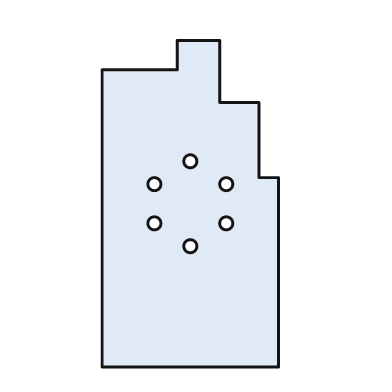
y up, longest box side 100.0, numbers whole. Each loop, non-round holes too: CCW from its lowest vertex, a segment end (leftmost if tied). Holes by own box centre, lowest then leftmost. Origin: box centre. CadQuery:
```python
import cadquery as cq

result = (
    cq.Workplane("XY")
    .moveTo(-27.0, -50.0)
    .lineTo(27.0, -50.0)
    .lineTo(27.0, 8.0)
    .lineTo(21.0, 8.0)
    .lineTo(21.0, 31.0)
    .lineTo(9.0, 31.0)
    .lineTo(9.0, 50.0)
    .lineTo(-4.0, 50.0)
    .lineTo(-4.0, 41.0)
    .lineTo(-27.0, 41.0)
    .close()
    .moveTo(0.0, -13.0)
    .circle(2.0)
    .moveTo(-11.0, -6.0)
    .circle(2.0)
    .moveTo(11.0, -6.0)
    .circle(2.0)
    .moveTo(-11.0, 6.0)
    .circle(2.0)
    .moveTo(11.0, 6.0)
    .circle(2.0)
    .moveTo(0.0, 13.0)
    .circle(2.0)
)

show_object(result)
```